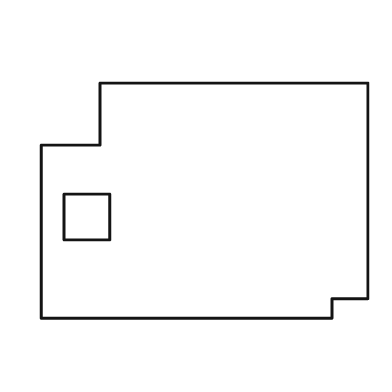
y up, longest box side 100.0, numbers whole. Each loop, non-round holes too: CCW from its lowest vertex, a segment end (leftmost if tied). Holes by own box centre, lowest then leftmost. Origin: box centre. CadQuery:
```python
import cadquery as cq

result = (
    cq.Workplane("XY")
    .moveTo(-50.0, -36.0)
    .lineTo(39.0, -36.0)
    .lineTo(39.0, -30.0)
    .lineTo(50.0, -30.0)
    .lineTo(50.0, 36.0)
    .lineTo(-32.0, 36.0)
    .lineTo(-32.0, 17.0)
    .lineTo(-50.0, 17.0)
    .close()
    .moveTo(-43.0, -12.0)
    .lineTo(-29.0, -12.0)
    .lineTo(-29.0, 2.0)
    .lineTo(-43.0, 2.0)
    .close()
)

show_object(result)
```